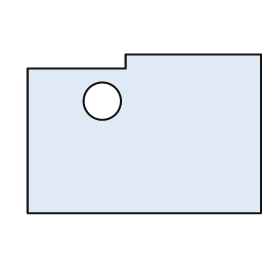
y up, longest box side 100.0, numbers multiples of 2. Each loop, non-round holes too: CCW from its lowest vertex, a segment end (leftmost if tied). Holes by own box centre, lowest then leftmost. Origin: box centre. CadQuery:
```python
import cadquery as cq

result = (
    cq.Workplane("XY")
    .moveTo(-50.0, -34.0)
    .lineTo(50.0, -34.0)
    .lineTo(50.0, 34.0)
    .lineTo(-8.0, 34.0)
    .lineTo(-8.0, 28.0)
    .lineTo(-50.0, 28.0)
    .close()
    .moveTo(-18.0, 14.0)
    .circle(8.0)
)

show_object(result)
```